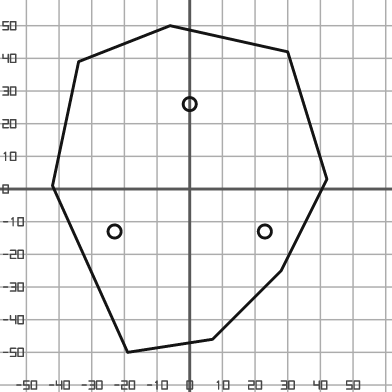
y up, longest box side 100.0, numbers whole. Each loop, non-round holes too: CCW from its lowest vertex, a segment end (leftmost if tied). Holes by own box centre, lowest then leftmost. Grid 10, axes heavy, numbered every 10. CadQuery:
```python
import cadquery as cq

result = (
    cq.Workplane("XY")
    .moveTo(-19.0, -50.0)
    .lineTo(7.0, -46.0)
    .lineTo(28.0, -25.0)
    .lineTo(42.0, 3.0)
    .lineTo(30.0, 42.0)
    .lineTo(-6.0, 50.0)
    .lineTo(-34.0, 39.0)
    .lineTo(-42.0, 1.0)
    .close()
    .moveTo(-23.0, -13.0)
    .circle(2.0)
    .moveTo(23.0, -13.0)
    .circle(2.0)
    .moveTo(0.0, 26.0)
    .circle(2.0)
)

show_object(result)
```